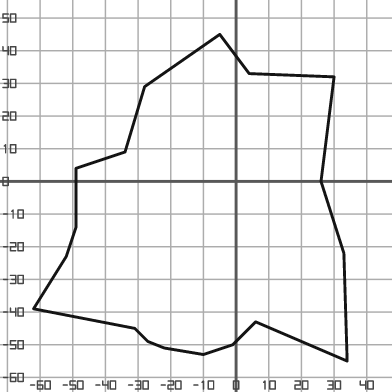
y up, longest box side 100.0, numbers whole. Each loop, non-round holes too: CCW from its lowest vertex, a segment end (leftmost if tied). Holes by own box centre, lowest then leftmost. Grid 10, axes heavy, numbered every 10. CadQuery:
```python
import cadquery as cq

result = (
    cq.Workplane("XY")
    .moveTo(34.0, -55.0)
    .lineTo(33.0, -22.0)
    .lineTo(26.0, 0.0)
    .lineTo(30.0, 32.0)
    .lineTo(4.0, 33.0)
    .lineTo(-5.0, 45.0)
    .lineTo(-28.0, 29.0)
    .lineTo(-34.0, 9.0)
    .lineTo(-49.0, 4.0)
    .lineTo(-49.0, -14.0)
    .lineTo(-52.0, -23.0)
    .lineTo(-62.0, -39.0)
    .lineTo(-31.0, -45.0)
    .lineTo(-27.0, -49.0)
    .lineTo(-22.0, -51.0)
    .lineTo(-10.0, -53.0)
    .lineTo(-1.0, -50.0)
    .lineTo(6.0, -43.0)
    .close()
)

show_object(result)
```